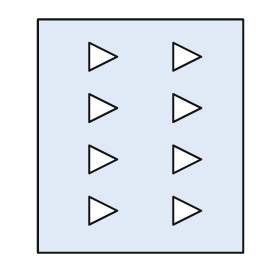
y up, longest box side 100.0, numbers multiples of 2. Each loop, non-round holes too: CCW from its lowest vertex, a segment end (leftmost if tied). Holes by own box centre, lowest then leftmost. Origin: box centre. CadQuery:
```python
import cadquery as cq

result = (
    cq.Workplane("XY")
    .moveTo(-44.0, -50.0)
    .lineTo(44.0, -50.0)
    .lineTo(44.0, 50.0)
    .lineTo(-44.0, 50.0)
    .close()
    .moveTo(-22.0, -38.0)
    .lineTo(-10.0, -32.0)
    .lineTo(-22.0, -26.0)
    .close()
    .moveTo(14.0, -38.0)
    .lineTo(26.0, -32.0)
    .lineTo(14.0, -26.0)
    .close()
    .moveTo(-22.0, -16.0)
    .lineTo(-10.0, -10.0)
    .lineTo(-22.0, -4.0)
    .close()
    .moveTo(14.0, -16.0)
    .lineTo(26.0, -10.0)
    .lineTo(14.0, -4.0)
    .close()
    .moveTo(-22.0, 6.0)
    .lineTo(-10.0, 12.0)
    .lineTo(-22.0, 18.0)
    .close()
    .moveTo(14.0, 6.0)
    .lineTo(26.0, 12.0)
    .lineTo(14.0, 18.0)
    .close()
    .moveTo(-22.0, 28.0)
    .lineTo(-10.0, 34.0)
    .lineTo(-22.0, 40.0)
    .close()
    .moveTo(14.0, 28.0)
    .lineTo(26.0, 34.0)
    .lineTo(14.0, 40.0)
    .close()
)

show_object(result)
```